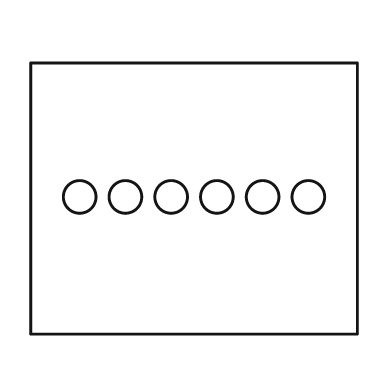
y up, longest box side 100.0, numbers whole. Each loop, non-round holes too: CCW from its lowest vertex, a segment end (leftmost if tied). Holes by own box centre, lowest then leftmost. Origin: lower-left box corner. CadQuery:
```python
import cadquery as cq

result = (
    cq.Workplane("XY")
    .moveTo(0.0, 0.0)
    .lineTo(100.0, 0.0)
    .lineTo(100.0, 83.0)
    .lineTo(0.0, 83.0)
    .close()
    .moveTo(15.0, 42.0)
    .circle(5.0)
    .moveTo(29.0, 42.0)
    .circle(5.0)
    .moveTo(43.0, 42.0)
    .circle(5.0)
    .moveTo(57.0, 42.0)
    .circle(5.0)
    .moveTo(71.0, 42.0)
    .circle(5.0)
    .moveTo(85.0, 42.0)
    .circle(5.0)
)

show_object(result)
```